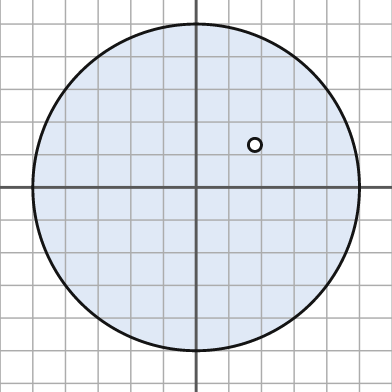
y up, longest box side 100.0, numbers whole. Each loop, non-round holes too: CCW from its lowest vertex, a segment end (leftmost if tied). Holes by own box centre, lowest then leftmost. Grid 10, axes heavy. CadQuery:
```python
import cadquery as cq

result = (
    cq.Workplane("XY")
    .moveTo(0.0, 0.0)
    .circle(50.0)
    .moveTo(18.0, 13.0)
    .circle(2.0)
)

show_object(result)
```